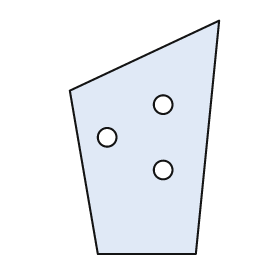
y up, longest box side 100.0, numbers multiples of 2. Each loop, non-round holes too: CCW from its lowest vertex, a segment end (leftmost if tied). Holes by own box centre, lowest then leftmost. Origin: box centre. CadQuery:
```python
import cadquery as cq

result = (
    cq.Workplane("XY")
    .moveTo(-20.0, -50.0)
    .lineTo(22.0, -50.0)
    .lineTo(32.0, 50.0)
    .lineTo(-32.0, 20.0)
    .close()
    .moveTo(8.0, -14.0)
    .circle(4.0)
    .moveTo(-16.0, 0.0)
    .circle(4.0)
    .moveTo(8.0, 14.0)
    .circle(4.0)
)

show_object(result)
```